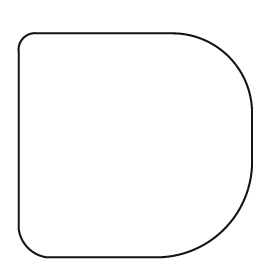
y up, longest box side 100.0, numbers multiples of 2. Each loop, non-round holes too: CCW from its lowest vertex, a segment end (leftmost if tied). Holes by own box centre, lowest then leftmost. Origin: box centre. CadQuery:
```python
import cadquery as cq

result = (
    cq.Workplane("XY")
    .moveTo(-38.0, -48.0)
    .lineTo(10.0, -48.0)
    .threePointArc((38.0, -36.0), (50.0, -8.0))
    .lineTo(50.0, 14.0)
    .threePointArc((40.0, 38.0), (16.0, 48.0))
    .lineTo(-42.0, 48.0)
    .threePointArc((-48.0, 46.0), (-50.0, 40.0))
    .lineTo(-50.0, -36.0)
    .threePointArc((-46.0, -44.0), (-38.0, -48.0))
    .close()
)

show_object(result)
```